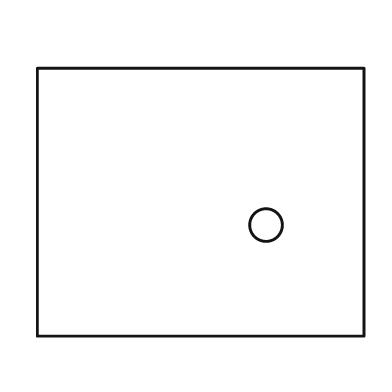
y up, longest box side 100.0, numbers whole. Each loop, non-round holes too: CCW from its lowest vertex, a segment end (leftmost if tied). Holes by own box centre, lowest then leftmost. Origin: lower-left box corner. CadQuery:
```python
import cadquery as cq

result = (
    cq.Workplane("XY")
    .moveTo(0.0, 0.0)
    .lineTo(100.0, 0.0)
    .lineTo(100.0, 82.0)
    .lineTo(0.0, 82.0)
    .close()
    .moveTo(70.0, 34.0)
    .circle(5.0)
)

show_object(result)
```